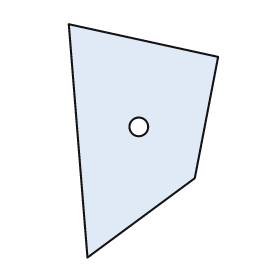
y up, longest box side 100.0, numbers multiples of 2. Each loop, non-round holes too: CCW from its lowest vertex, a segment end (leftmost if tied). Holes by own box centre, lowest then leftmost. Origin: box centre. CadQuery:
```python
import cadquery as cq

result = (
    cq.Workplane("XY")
    .moveTo(-24.0, -50.0)
    .lineTo(22.0, -16.0)
    .lineTo(32.0, 36.0)
    .lineTo(-32.0, 50.0)
    .close()
    .moveTo(-2.0, 6.0)
    .circle(4.0)
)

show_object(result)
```